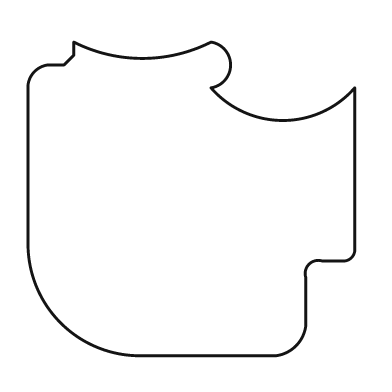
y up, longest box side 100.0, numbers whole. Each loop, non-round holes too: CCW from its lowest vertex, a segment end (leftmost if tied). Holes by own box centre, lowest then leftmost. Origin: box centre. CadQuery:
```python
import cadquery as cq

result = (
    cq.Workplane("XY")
    .moveTo(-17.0, -48.0)
    .lineTo(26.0, -48.0)
    .threePointArc((32.0, -45.0), (35.0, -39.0))
    .lineTo(35.0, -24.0)
    .threePointArc((36.0, -20.0), (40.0, -19.0))
    .lineTo(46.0, -19.0)
    .threePointArc((49.0, -18.0), (50.0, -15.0))
    .lineTo(50.0, 34.0)
    .threePointArc((28.0, 24.0), (6.0, 34.0))
    .threePointArc((12.0, 41.0), (6.0, 48.0))
    .threePointArc((-15.0, 43.0), (-36.0, 48.0))
    .lineTo(-36.0, 44.0)
    .lineTo(-39.0, 41.0)
    .lineTo(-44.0, 41.0)
    .threePointArc((-48.0, 39.0), (-50.0, 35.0))
    .lineTo(-50.0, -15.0)
    .threePointArc((-40.0, -38.0), (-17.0, -48.0))
    .close()
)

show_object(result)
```